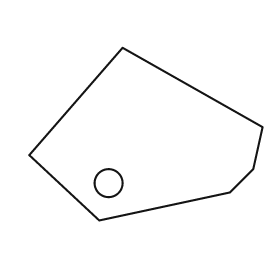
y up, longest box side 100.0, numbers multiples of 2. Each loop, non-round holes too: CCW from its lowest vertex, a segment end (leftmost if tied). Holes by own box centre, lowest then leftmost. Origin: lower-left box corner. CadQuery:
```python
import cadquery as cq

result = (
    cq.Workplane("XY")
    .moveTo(30.0, 0.0)
    .lineTo(86.0, 12.0)
    .lineTo(96.0, 22.0)
    .lineTo(100.0, 40.0)
    .lineTo(40.0, 74.0)
    .lineTo(0.0, 28.0)
    .close()
    .moveTo(34.0, 16.0)
    .circle(6.0)
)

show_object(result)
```